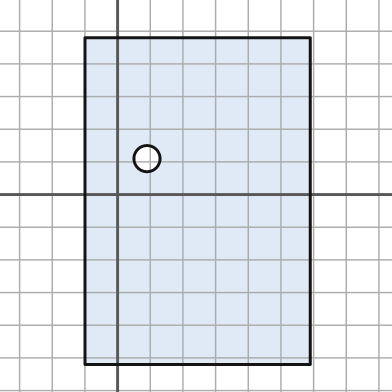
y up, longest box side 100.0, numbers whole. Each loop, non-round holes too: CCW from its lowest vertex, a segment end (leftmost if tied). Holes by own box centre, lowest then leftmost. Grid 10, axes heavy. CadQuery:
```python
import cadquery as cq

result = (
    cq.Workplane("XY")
    .moveTo(-10.0, -52.0)
    .lineTo(59.0, -52.0)
    .lineTo(59.0, 48.0)
    .lineTo(-10.0, 48.0)
    .close()
    .moveTo(9.0, 11.0)
    .circle(4.0)
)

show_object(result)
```